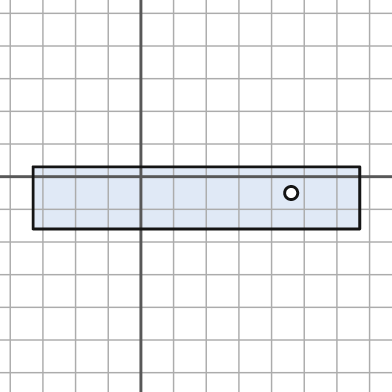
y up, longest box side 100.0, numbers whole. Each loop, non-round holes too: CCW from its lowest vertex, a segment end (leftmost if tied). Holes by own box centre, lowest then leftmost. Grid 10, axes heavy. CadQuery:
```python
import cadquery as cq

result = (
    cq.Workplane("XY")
    .moveTo(-33.0, -16.0)
    .lineTo(67.0, -16.0)
    .lineTo(67.0, 3.0)
    .lineTo(-33.0, 3.0)
    .close()
    .moveTo(46.0, -5.0)
    .circle(2.0)
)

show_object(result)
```